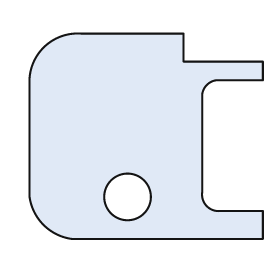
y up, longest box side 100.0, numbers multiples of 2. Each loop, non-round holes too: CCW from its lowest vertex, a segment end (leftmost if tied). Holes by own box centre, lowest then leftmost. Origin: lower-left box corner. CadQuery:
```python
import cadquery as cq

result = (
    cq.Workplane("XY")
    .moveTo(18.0, 0.0)
    .lineTo(100.0, 0.0)
    .lineTo(100.0, 12.0)
    .lineTo(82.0, 12.0)
    .threePointArc((76.0, 14.0), (74.0, 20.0))
    .lineTo(74.0, 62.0)
    .threePointArc((76.0, 66.0), (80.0, 68.0))
    .lineTo(100.0, 68.0)
    .lineTo(100.0, 76.0)
    .lineTo(66.0, 76.0)
    .lineTo(66.0, 88.0)
    .lineTo(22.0, 88.0)
    .threePointArc((6.0, 82.0), (0.0, 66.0))
    .lineTo(0.0, 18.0)
    .threePointArc((6.0, 6.0), (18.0, 0.0))
    .close()
    .moveTo(42.0, 18.0)
    .circle(10.0)
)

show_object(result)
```